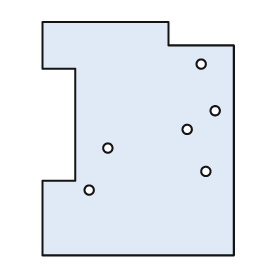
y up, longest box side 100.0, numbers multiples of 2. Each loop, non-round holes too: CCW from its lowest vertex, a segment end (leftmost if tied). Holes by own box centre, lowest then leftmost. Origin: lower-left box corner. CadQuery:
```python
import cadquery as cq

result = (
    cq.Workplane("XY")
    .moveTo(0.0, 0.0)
    .lineTo(82.0, 0.0)
    .lineTo(82.0, 90.0)
    .lineTo(54.0, 90.0)
    .lineTo(54.0, 100.0)
    .lineTo(0.0, 100.0)
    .lineTo(0.0, 80.0)
    .lineTo(14.0, 80.0)
    .lineTo(14.0, 32.0)
    .lineTo(0.0, 32.0)
    .close()
    .moveTo(20.0, 28.0)
    .circle(2.0)
    .moveTo(70.0, 36.0)
    .circle(2.0)
    .moveTo(28.0, 46.0)
    .circle(2.0)
    .moveTo(62.0, 54.0)
    .circle(2.0)
    .moveTo(74.0, 62.0)
    .circle(2.0)
    .moveTo(68.0, 82.0)
    .circle(2.0)
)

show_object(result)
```